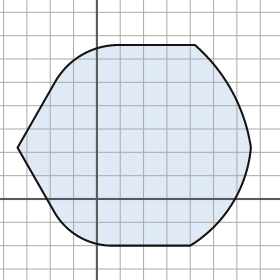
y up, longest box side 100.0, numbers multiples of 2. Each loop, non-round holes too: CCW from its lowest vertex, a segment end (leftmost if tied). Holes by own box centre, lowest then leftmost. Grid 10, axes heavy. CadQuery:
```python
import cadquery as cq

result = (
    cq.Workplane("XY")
    .moveTo(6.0, -20.0)
    .lineTo(40.0, -20.0)
    .threePointArc((58.0, -2.0), (66.0, 22.0))
    .threePointArc((58.0, 46.0), (42.0, 66.0))
    .lineTo(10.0, 66.0)
    .threePointArc((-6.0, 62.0), (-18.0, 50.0))
    .lineTo(-34.0, 22.0)
    .lineTo(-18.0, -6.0)
    .threePointArc((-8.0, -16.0), (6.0, -20.0))
    .close()
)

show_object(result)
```